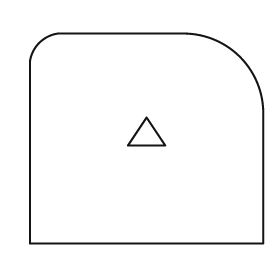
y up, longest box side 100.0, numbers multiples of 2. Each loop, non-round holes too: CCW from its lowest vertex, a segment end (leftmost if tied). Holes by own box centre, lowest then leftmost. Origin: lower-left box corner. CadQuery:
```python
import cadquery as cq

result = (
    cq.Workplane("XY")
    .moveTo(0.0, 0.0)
    .lineTo(100.0, 0.0)
    .lineTo(100.0, 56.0)
    .threePointArc((90.0, 80.0), (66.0, 90.0))
    .lineTo(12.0, 90.0)
    .threePointArc((4.0, 86.0), (0.0, 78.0))
    .close()
    .moveTo(42.0, 42.0)
    .lineTo(58.0, 42.0)
    .lineTo(50.0, 54.0)
    .close()
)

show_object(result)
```